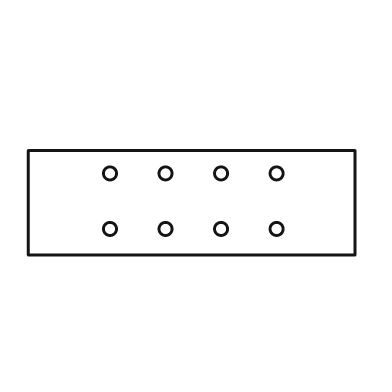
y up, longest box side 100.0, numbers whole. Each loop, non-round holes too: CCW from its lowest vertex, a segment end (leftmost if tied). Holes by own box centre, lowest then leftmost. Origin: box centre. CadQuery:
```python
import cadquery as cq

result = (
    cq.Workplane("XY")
    .moveTo(-50.0, -16.0)
    .lineTo(50.0, -16.0)
    .lineTo(50.0, 16.0)
    .lineTo(-50.0, 16.0)
    .close()
    .moveTo(-25.0, -8.0)
    .circle(2.0)
    .moveTo(-8.0, -8.0)
    .circle(2.0)
    .moveTo(9.0, -8.0)
    .circle(2.0)
    .moveTo(26.0, -8.0)
    .circle(2.0)
    .moveTo(-25.0, 9.0)
    .circle(2.0)
    .moveTo(-8.0, 9.0)
    .circle(2.0)
    .moveTo(9.0, 9.0)
    .circle(2.0)
    .moveTo(26.0, 9.0)
    .circle(2.0)
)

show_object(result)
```